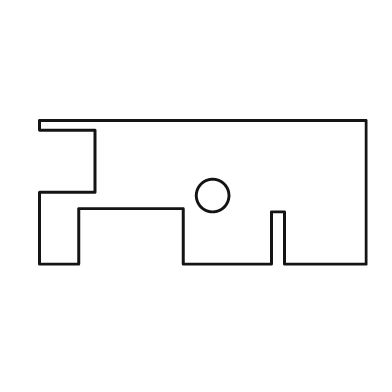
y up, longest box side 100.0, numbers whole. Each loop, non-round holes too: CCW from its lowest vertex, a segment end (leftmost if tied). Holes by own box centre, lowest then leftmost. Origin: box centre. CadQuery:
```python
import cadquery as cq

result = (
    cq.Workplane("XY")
    .moveTo(-50.0, -22.0)
    .lineTo(-38.0, -22.0)
    .lineTo(-38.0, -5.0)
    .lineTo(-6.0, -5.0)
    .lineTo(-6.0, -22.0)
    .lineTo(21.0, -22.0)
    .lineTo(21.0, -6.0)
    .lineTo(25.0, -6.0)
    .lineTo(25.0, -22.0)
    .lineTo(50.0, -22.0)
    .lineTo(50.0, 22.0)
    .lineTo(-50.0, 22.0)
    .lineTo(-50.0, 19.0)
    .lineTo(-33.0, 19.0)
    .lineTo(-33.0, 0.0)
    .lineTo(-50.0, 0.0)
    .close()
    .moveTo(3.0, -1.0)
    .circle(5.0)
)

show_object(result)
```